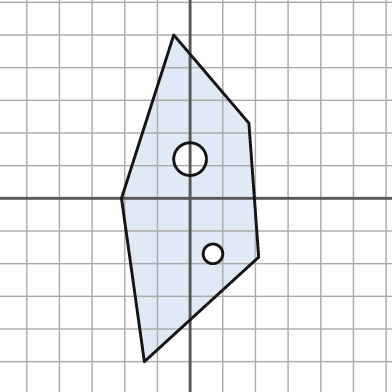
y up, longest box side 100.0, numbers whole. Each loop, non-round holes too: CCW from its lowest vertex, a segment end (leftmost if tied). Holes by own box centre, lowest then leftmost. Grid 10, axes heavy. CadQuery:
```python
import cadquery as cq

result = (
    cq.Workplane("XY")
    .moveTo(-14.0, -50.0)
    .lineTo(21.0, -18.0)
    .lineTo(18.0, 23.0)
    .lineTo(-5.0, 50.0)
    .lineTo(-21.0, 0.0)
    .close()
    .moveTo(7.0, -17.0)
    .circle(3.0)
    .moveTo(0.0, 12.0)
    .circle(5.0)
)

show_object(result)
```